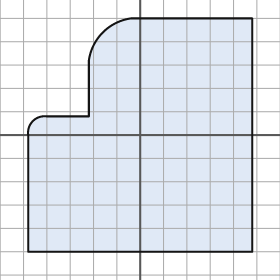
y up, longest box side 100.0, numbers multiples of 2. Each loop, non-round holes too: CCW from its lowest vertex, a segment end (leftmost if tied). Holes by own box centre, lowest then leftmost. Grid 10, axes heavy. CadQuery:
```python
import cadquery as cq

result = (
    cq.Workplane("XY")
    .moveTo(-48.0, -50.0)
    .lineTo(48.0, -50.0)
    .lineTo(48.0, 50.0)
    .lineTo(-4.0, 50.0)
    .threePointArc((-16.0, 44.0), (-22.0, 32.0))
    .lineTo(-22.0, 8.0)
    .lineTo(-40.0, 8.0)
    .threePointArc((-46.0, 6.0), (-48.0, 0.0))
    .close()
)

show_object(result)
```